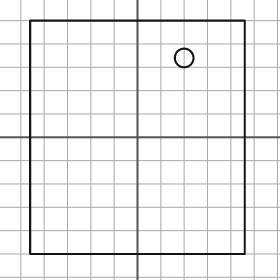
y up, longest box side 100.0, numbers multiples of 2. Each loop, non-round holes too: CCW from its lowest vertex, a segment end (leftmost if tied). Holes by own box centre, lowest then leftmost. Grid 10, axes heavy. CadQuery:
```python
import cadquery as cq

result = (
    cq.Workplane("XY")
    .moveTo(-46.0, -50.0)
    .lineTo(46.0, -50.0)
    .lineTo(46.0, 50.0)
    .lineTo(-46.0, 50.0)
    .close()
    .moveTo(20.0, 34.0)
    .circle(4.0)
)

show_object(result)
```